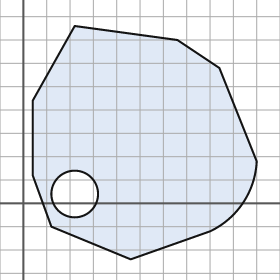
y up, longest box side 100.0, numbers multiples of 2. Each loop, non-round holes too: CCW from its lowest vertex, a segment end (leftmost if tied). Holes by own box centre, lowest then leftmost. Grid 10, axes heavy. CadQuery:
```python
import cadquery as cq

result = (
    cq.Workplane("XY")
    .moveTo(46.0, -24.0)
    .lineTo(80.0, -12.0)
    .threePointArc((94.0, 0.0), (100.0, 18.0))
    .lineTo(84.0, 58.0)
    .lineTo(66.0, 70.0)
    .lineTo(22.0, 76.0)
    .lineTo(4.0, 44.0)
    .lineTo(4.0, 12.0)
    .lineTo(12.0, -10.0)
    .close()
    .moveTo(22.0, 4.0)
    .circle(10.0)
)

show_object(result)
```